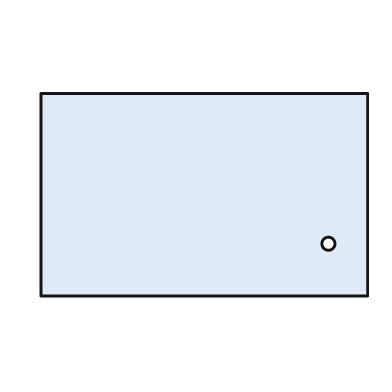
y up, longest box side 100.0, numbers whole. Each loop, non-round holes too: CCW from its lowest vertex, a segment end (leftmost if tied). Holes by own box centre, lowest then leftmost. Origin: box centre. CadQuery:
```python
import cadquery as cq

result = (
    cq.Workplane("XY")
    .moveTo(-50.0, -31.0)
    .lineTo(50.0, -31.0)
    .lineTo(50.0, 31.0)
    .lineTo(-50.0, 31.0)
    .close()
    .moveTo(38.0, -15.0)
    .circle(2.0)
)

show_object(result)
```